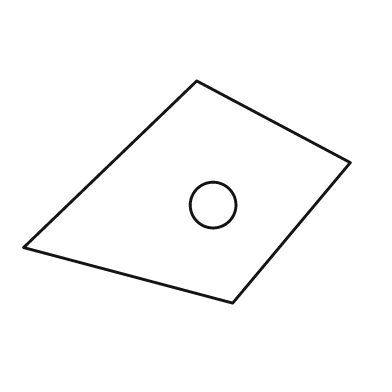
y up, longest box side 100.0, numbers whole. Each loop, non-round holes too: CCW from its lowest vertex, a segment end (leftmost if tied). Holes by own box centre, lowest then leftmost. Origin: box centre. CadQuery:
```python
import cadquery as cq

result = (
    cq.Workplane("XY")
    .moveTo(14.0, -34.0)
    .lineTo(50.0, 9.0)
    .lineTo(3.0, 34.0)
    .lineTo(-50.0, -17.0)
    .close()
    .moveTo(8.0, -4.0)
    .circle(7.0)
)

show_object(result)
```